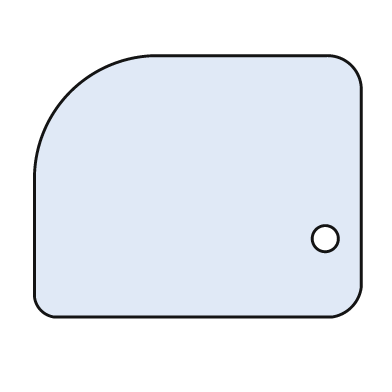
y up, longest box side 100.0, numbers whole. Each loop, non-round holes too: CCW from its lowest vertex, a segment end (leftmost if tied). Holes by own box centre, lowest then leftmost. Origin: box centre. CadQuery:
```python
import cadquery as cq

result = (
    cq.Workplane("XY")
    .moveTo(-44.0, -40.0)
    .lineTo(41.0, -40.0)
    .threePointArc((47.0, -37.0), (50.0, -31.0))
    .lineTo(50.0, 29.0)
    .threePointArc((47.0, 37.0), (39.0, 40.0))
    .lineTo(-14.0, 40.0)
    .threePointArc((-39.0, 29.0), (-50.0, 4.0))
    .lineTo(-50.0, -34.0)
    .threePointArc((-48.0, -38.0), (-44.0, -40.0))
    .close()
    .moveTo(39.0, -16.0)
    .circle(4.0)
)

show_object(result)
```